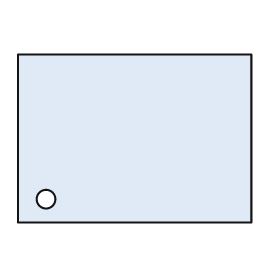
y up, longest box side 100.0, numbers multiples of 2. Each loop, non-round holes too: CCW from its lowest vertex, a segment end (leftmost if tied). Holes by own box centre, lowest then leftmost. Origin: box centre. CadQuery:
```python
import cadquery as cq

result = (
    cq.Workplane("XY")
    .moveTo(-50.0, -36.0)
    .lineTo(50.0, -36.0)
    .lineTo(50.0, 36.0)
    .lineTo(-50.0, 36.0)
    .close()
    .moveTo(-38.0, -26.0)
    .circle(4.0)
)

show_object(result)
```